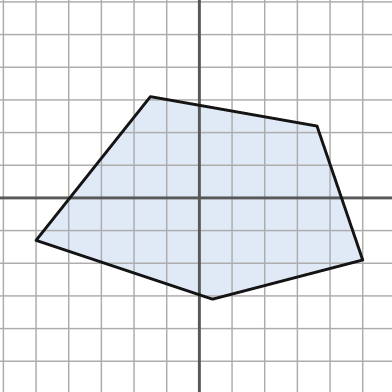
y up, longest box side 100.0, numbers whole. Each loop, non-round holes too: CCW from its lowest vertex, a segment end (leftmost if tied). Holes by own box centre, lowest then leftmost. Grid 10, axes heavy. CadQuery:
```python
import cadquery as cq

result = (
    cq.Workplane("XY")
    .moveTo(4.0, -31.0)
    .lineTo(50.0, -19.0)
    .lineTo(36.0, 22.0)
    .lineTo(-15.0, 31.0)
    .lineTo(-50.0, -13.0)
    .close()
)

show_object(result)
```